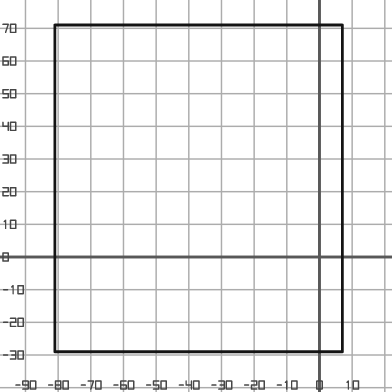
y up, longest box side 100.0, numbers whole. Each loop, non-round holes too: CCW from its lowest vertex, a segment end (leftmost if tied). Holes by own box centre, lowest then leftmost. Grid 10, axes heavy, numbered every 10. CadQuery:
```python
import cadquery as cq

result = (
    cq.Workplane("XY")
    .moveTo(-81.0, -29.0)
    .lineTo(7.0, -29.0)
    .lineTo(7.0, 71.0)
    .lineTo(-81.0, 71.0)
    .close()
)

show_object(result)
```